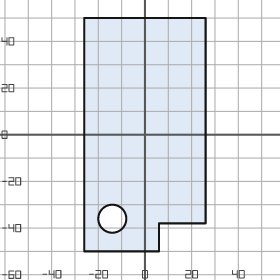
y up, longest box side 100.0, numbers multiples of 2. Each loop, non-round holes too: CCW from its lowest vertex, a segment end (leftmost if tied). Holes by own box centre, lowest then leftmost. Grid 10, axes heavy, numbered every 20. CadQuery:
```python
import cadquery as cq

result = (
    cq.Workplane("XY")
    .moveTo(-26.0, -50.0)
    .lineTo(6.0, -50.0)
    .lineTo(6.0, -38.0)
    .lineTo(26.0, -38.0)
    .lineTo(26.0, 50.0)
    .lineTo(-26.0, 50.0)
    .close()
    .moveTo(-14.0, -36.0)
    .circle(6.0)
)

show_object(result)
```